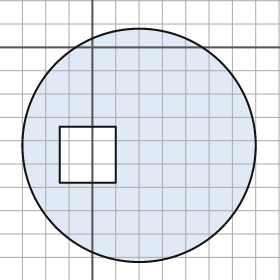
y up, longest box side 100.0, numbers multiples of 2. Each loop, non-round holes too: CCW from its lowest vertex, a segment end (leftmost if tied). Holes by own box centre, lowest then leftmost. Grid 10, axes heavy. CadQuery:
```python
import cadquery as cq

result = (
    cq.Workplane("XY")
    .moveTo(20.0, -42.0)
    .circle(50.0)
    .moveTo(-14.0, -58.0)
    .lineTo(10.0, -58.0)
    .lineTo(10.0, -34.0)
    .lineTo(-14.0, -34.0)
    .close()
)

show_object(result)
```